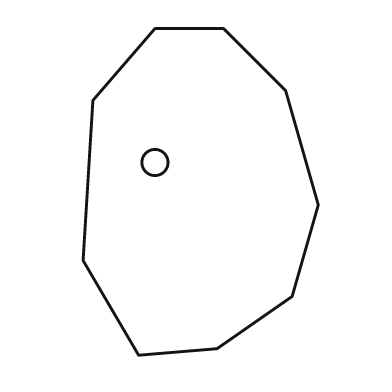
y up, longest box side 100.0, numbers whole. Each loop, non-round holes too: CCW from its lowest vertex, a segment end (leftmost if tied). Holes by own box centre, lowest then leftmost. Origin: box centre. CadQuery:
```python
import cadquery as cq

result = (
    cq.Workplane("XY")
    .moveTo(-19.0, -50.0)
    .lineTo(5.0, -48.0)
    .lineTo(28.0, -32.0)
    .lineTo(36.0, -4.0)
    .lineTo(26.0, 31.0)
    .lineTo(7.0, 50.0)
    .lineTo(-14.0, 50.0)
    .lineTo(-33.0, 28.0)
    .lineTo(-36.0, -21.0)
    .close()
    .moveTo(-14.0, 9.0)
    .circle(4.0)
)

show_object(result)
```